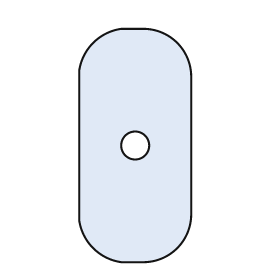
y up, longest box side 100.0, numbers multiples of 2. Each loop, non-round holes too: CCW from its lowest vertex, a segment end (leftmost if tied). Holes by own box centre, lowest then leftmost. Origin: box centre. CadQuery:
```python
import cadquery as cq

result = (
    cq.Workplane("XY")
    .moveTo(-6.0, -50.0)
    .lineTo(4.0, -50.0)
    .threePointArc((18.0, -44.0), (24.0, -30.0))
    .lineTo(24.0, 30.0)
    .threePointArc((18.0, 44.0), (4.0, 50.0))
    .lineTo(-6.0, 50.0)
    .threePointArc((-18.0, 44.0), (-24.0, 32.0))
    .lineTo(-24.0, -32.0)
    .threePointArc((-18.0, -44.0), (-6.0, -50.0))
    .close()
    .moveTo(0.0, 0.0)
    .circle(6.0)
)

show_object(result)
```